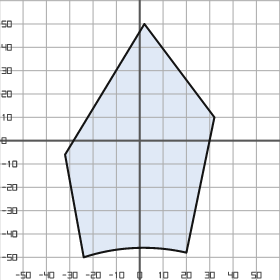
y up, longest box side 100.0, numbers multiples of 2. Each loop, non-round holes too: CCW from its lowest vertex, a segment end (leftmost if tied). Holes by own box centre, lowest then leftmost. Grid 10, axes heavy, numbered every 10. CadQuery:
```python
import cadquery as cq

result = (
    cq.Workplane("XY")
    .moveTo(-24.0, -50.0)
    .threePointArc((-2.0, -46.0), (20.0, -48.0))
    .lineTo(32.0, 10.0)
    .lineTo(2.0, 50.0)
    .lineTo(-32.0, -6.0)
    .close()
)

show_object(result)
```